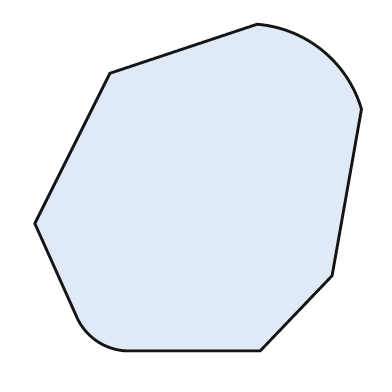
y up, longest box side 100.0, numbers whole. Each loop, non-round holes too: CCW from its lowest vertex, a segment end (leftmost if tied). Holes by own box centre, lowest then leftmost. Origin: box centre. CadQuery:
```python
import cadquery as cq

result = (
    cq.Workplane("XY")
    .moveTo(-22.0, -50.0)
    .lineTo(19.0, -50.0)
    .lineTo(41.0, -27.0)
    .lineTo(50.0, 24.0)
    .threePointArc((38.0, 42.0), (18.0, 50.0))
    .lineTo(-27.0, 35.0)
    .lineTo(-50.0, -11.0)
    .lineTo(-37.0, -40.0)
    .threePointArc((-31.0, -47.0), (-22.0, -50.0))
    .close()
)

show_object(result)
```